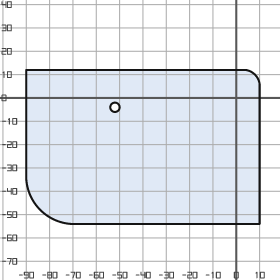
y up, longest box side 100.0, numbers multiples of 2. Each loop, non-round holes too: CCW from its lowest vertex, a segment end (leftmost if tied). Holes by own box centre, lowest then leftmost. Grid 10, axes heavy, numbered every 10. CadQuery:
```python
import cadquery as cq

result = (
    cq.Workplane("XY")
    .moveTo(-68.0, -54.0)
    .lineTo(10.0, -54.0)
    .lineTo(10.0, 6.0)
    .threePointArc((8.0, 10.0), (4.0, 12.0))
    .lineTo(-90.0, 12.0)
    .lineTo(-90.0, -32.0)
    .threePointArc((-84.0, -48.0), (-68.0, -54.0))
    .close()
    .moveTo(-52.0, -4.0)
    .circle(2.0)
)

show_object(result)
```